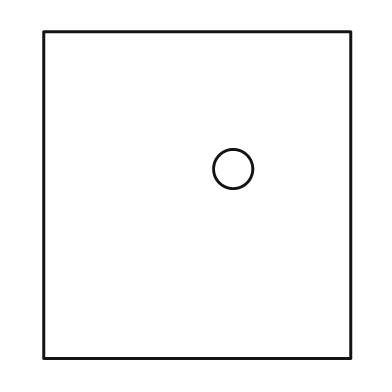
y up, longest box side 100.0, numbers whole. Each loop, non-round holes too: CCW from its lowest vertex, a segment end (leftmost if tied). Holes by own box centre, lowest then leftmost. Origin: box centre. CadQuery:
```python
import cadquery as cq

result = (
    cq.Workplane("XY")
    .moveTo(-47.0, -50.0)
    .lineTo(47.0, -50.0)
    .lineTo(47.0, 50.0)
    .lineTo(-47.0, 50.0)
    .close()
    .moveTo(11.0, 8.0)
    .circle(6.0)
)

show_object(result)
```